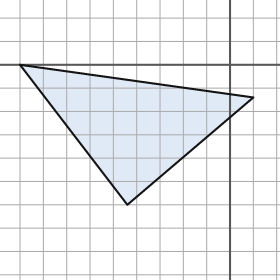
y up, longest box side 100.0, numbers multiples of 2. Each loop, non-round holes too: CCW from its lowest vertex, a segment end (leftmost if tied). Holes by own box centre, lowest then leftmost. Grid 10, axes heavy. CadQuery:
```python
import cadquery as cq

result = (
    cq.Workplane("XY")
    .moveTo(-44.0, -60.0)
    .lineTo(10.0, -14.0)
    .lineTo(-90.0, 0.0)
    .close()
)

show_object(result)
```